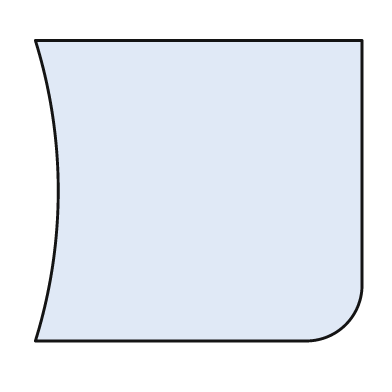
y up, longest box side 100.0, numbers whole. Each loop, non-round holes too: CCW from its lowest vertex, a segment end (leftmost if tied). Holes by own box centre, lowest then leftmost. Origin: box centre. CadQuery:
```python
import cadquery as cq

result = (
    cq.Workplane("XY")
    .moveTo(-50.0, -46.0)
    .lineTo(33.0, -46.0)
    .threePointArc((45.0, -41.0), (50.0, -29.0))
    .lineTo(50.0, 46.0)
    .lineTo(-50.0, 46.0)
    .threePointArc((-43.0, 0.0), (-50.0, -46.0))
    .close()
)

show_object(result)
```